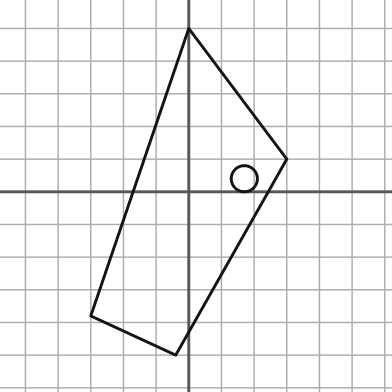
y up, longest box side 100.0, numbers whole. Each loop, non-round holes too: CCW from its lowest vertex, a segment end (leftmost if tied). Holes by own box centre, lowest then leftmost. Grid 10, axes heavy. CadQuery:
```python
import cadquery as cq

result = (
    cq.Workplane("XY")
    .moveTo(-4.0, -50.0)
    .lineTo(30.0, 10.0)
    .lineTo(0.0, 50.0)
    .lineTo(-30.0, -38.0)
    .close()
    .moveTo(17.0, 4.0)
    .circle(4.0)
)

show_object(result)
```